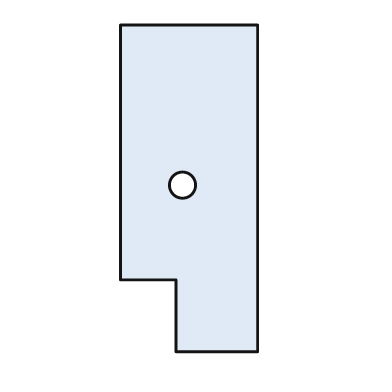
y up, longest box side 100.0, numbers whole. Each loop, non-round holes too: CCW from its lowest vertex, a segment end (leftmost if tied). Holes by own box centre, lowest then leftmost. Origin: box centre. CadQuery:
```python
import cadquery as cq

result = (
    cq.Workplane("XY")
    .moveTo(-4.0, -50.0)
    .lineTo(21.0, -50.0)
    .lineTo(21.0, 50.0)
    .lineTo(-21.0, 50.0)
    .lineTo(-21.0, -28.0)
    .lineTo(-4.0, -28.0)
    .close()
    .moveTo(-2.0, 1.0)
    .circle(4.0)
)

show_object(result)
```